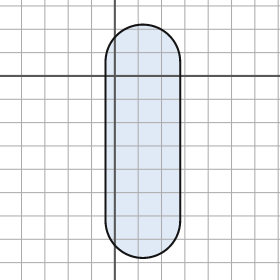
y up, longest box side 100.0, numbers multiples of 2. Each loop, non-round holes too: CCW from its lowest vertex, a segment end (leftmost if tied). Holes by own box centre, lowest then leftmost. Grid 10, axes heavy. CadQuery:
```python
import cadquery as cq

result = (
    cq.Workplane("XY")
    .moveTo(-4.0, -62.0)
    .threePointArc((12.0, -78.0), (28.0, -62.0))
    .lineTo(28.0, 6.0)
    .threePointArc((12.0, 22.0), (-4.0, 6.0))
    .close()
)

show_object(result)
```